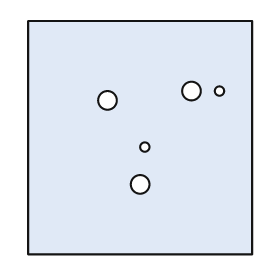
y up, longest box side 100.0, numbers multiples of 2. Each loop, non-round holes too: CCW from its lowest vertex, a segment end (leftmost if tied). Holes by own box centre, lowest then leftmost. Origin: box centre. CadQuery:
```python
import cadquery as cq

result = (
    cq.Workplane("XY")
    .moveTo(-48.0, -50.0)
    .lineTo(48.0, -50.0)
    .lineTo(48.0, 50.0)
    .lineTo(-48.0, 50.0)
    .close()
    .moveTo(0.0, -20.0)
    .circle(4.0)
    .moveTo(2.0, -4.0)
    .circle(2.0)
    .moveTo(-14.0, 16.0)
    .circle(4.0)
    .moveTo(22.0, 20.0)
    .circle(4.0)
    .moveTo(34.0, 20.0)
    .circle(2.0)
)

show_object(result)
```